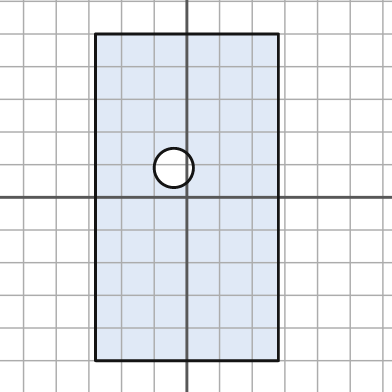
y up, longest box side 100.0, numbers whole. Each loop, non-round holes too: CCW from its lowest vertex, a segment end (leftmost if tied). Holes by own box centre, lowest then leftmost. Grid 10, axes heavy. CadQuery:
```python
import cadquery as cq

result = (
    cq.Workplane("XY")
    .moveTo(-28.0, -50.0)
    .lineTo(28.0, -50.0)
    .lineTo(28.0, 50.0)
    .lineTo(-28.0, 50.0)
    .close()
    .moveTo(-4.0, 9.0)
    .circle(6.0)
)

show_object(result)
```